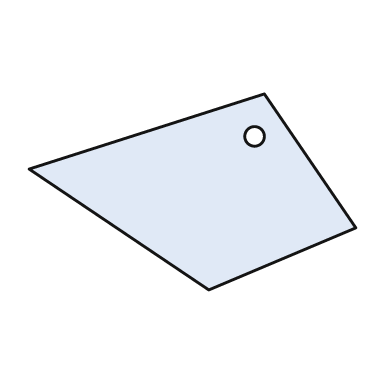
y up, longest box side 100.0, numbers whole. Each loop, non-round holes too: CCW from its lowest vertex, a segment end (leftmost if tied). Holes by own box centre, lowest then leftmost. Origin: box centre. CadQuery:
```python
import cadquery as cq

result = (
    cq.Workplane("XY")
    .moveTo(5.0, -30.0)
    .lineTo(50.0, -11.0)
    .lineTo(22.0, 30.0)
    .lineTo(-50.0, 7.0)
    .close()
    .moveTo(19.0, 17.0)
    .circle(3.0)
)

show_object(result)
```